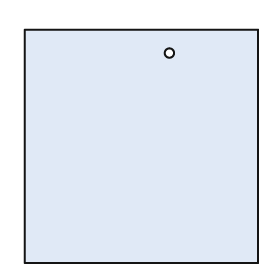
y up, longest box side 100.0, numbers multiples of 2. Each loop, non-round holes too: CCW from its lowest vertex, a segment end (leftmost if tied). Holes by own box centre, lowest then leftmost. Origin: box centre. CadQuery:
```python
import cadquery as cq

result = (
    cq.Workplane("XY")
    .moveTo(-50.0, -50.0)
    .lineTo(50.0, -50.0)
    .lineTo(50.0, 50.0)
    .lineTo(-50.0, 50.0)
    .close()
    .moveTo(12.0, 40.0)
    .circle(2.0)
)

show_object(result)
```